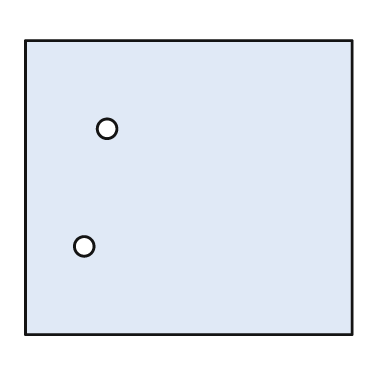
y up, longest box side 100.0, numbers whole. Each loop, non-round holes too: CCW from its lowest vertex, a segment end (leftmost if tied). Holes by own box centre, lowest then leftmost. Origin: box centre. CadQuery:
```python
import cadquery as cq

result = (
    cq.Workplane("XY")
    .moveTo(-50.0, -45.0)
    .lineTo(50.0, -45.0)
    .lineTo(50.0, 45.0)
    .lineTo(-50.0, 45.0)
    .close()
    .moveTo(-32.0, -18.0)
    .circle(3.0)
    .moveTo(-25.0, 18.0)
    .circle(3.0)
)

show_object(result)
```